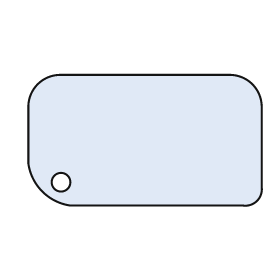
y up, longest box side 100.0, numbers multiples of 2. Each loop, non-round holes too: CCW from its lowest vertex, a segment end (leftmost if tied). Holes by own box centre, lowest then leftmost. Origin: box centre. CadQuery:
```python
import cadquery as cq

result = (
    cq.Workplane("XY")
    .moveTo(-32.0, -28.0)
    .lineTo(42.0, -28.0)
    .threePointArc((48.0, -26.0), (50.0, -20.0))
    .lineTo(50.0, 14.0)
    .threePointArc((46.0, 24.0), (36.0, 28.0))
    .lineTo(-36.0, 28.0)
    .threePointArc((-46.0, 24.0), (-50.0, 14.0))
    .lineTo(-50.0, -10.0)
    .threePointArc((-44.0, -22.0), (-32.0, -28.0))
    .close()
    .moveTo(-36.0, -18.0)
    .circle(4.0)
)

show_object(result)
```